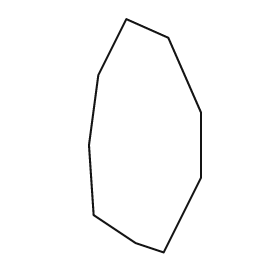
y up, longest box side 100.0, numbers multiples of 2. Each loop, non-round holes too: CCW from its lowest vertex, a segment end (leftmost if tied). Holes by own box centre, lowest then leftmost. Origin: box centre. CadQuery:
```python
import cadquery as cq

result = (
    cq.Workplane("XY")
    .moveTo(8.0, -50.0)
    .lineTo(24.0, -18.0)
    .lineTo(24.0, 10.0)
    .lineTo(10.0, 42.0)
    .lineTo(-8.0, 50.0)
    .lineTo(-20.0, 26.0)
    .lineTo(-24.0, -4.0)
    .lineTo(-22.0, -34.0)
    .lineTo(-4.0, -46.0)
    .close()
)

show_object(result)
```